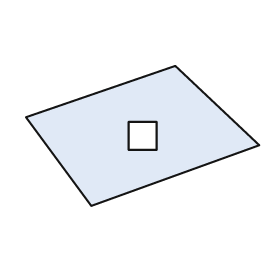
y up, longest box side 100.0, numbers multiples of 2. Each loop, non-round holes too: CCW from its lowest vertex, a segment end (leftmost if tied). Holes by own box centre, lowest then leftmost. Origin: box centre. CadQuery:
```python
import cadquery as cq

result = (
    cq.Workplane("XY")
    .moveTo(-22.0, -30.0)
    .lineTo(50.0, -4.0)
    .lineTo(14.0, 30.0)
    .lineTo(-50.0, 8.0)
    .close()
    .moveTo(-6.0, -6.0)
    .lineTo(6.0, -6.0)
    .lineTo(6.0, 6.0)
    .lineTo(-6.0, 6.0)
    .close()
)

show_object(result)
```